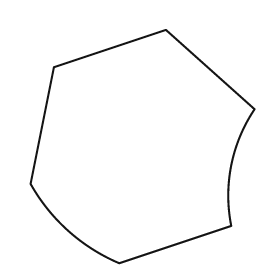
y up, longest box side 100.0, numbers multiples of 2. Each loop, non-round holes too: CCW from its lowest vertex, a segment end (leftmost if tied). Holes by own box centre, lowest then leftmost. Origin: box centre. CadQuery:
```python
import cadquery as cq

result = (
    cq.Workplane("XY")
    .moveTo(-10.0, -50.0)
    .lineTo(38.0, -34.0)
    .threePointArc((38.0, -8.0), (48.0, 16.0))
    .lineTo(10.0, 50.0)
    .lineTo(-38.0, 34.0)
    .lineTo(-48.0, -16.0)
    .threePointArc((-32.0, -36.0), (-10.0, -50.0))
    .close()
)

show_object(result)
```